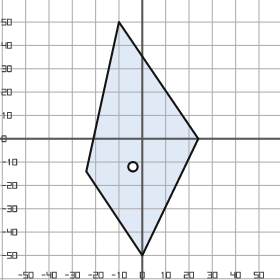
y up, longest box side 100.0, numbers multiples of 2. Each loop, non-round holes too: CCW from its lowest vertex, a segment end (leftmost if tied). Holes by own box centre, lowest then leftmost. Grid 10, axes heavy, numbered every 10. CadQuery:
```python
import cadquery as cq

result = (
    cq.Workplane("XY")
    .moveTo(0.0, -50.0)
    .lineTo(24.0, 0.0)
    .lineTo(-10.0, 50.0)
    .lineTo(-24.0, -14.0)
    .close()
    .moveTo(-4.0, -12.0)
    .circle(2.0)
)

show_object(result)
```